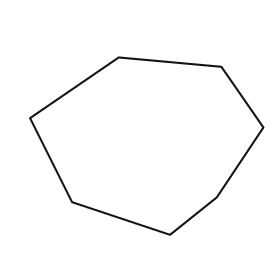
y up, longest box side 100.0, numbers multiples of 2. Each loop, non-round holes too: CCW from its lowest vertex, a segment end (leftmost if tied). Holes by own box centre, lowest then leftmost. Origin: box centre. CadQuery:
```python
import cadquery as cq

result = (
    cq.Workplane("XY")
    .moveTo(10.0, -38.0)
    .lineTo(30.0, -22.0)
    .lineTo(50.0, 8.0)
    .lineTo(32.0, 34.0)
    .lineTo(-12.0, 38.0)
    .lineTo(-50.0, 12.0)
    .lineTo(-32.0, -24.0)
    .close()
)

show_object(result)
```